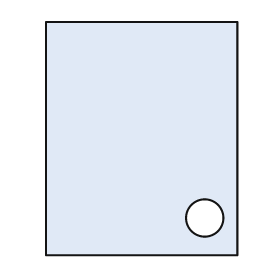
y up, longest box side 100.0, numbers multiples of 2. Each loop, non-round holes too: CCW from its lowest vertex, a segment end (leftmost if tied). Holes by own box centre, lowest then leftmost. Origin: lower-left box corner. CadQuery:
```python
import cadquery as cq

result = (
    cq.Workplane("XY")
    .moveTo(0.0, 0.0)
    .lineTo(82.0, 0.0)
    .lineTo(82.0, 100.0)
    .lineTo(0.0, 100.0)
    .close()
    .moveTo(68.0, 16.0)
    .circle(8.0)
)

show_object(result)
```